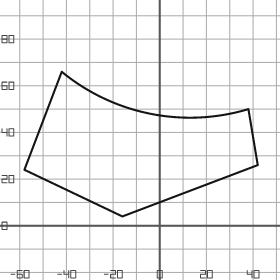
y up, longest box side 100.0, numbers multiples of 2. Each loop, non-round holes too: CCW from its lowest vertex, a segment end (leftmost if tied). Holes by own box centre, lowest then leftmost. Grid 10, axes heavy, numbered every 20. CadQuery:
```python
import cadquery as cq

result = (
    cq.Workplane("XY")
    .moveTo(-16.0, 4.0)
    .lineTo(42.0, 26.0)
    .lineTo(38.0, 50.0)
    .threePointArc((-4.0, 48.0), (-42.0, 66.0))
    .lineTo(-58.0, 24.0)
    .close()
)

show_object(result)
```